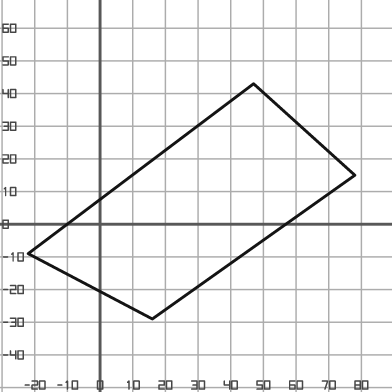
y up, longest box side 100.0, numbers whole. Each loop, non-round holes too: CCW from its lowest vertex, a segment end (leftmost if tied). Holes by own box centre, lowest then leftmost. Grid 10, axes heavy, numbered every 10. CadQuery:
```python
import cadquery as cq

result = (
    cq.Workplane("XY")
    .moveTo(16.0, -29.0)
    .lineTo(78.0, 15.0)
    .lineTo(47.0, 43.0)
    .lineTo(-22.0, -9.0)
    .close()
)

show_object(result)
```